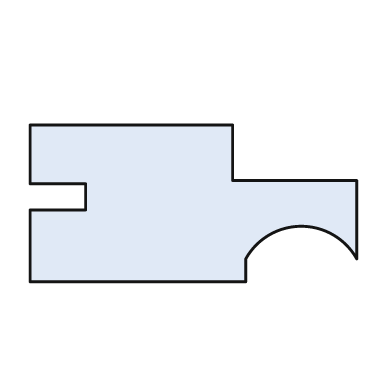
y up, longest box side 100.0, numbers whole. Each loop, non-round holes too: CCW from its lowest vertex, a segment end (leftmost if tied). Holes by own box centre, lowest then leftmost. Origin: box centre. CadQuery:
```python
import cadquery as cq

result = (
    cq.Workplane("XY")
    .moveTo(-50.0, -24.0)
    .lineTo(16.0, -24.0)
    .lineTo(16.0, -17.0)
    .threePointArc((33.0, -7.0), (50.0, -17.0))
    .lineTo(50.0, 7.0)
    .lineTo(12.0, 7.0)
    .lineTo(12.0, 24.0)
    .lineTo(-50.0, 24.0)
    .lineTo(-50.0, 6.0)
    .lineTo(-33.0, 6.0)
    .lineTo(-33.0, -2.0)
    .lineTo(-50.0, -2.0)
    .close()
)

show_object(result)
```